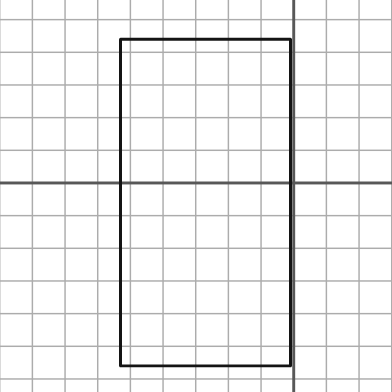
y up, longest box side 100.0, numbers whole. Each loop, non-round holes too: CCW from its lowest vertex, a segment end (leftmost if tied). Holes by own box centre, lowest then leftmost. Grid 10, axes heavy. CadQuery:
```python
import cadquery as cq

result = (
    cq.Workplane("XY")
    .moveTo(-53.0, -56.0)
    .lineTo(-1.0, -56.0)
    .lineTo(-1.0, 44.0)
    .lineTo(-53.0, 44.0)
    .close()
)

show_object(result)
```